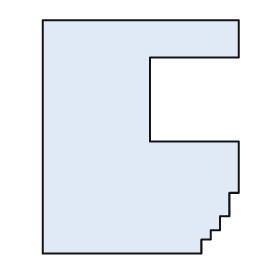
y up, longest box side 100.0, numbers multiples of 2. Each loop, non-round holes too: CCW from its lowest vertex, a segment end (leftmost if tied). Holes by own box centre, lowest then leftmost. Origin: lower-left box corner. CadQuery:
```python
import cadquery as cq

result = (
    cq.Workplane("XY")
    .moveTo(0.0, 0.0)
    .lineTo(68.0, 0.0)
    .lineTo(68.0, 6.0)
    .lineTo(72.0, 6.0)
    .lineTo(72.0, 10.0)
    .lineTo(76.0, 10.0)
    .lineTo(76.0, 16.0)
    .lineTo(80.0, 16.0)
    .lineTo(80.0, 26.0)
    .lineTo(84.0, 26.0)
    .lineTo(84.0, 48.0)
    .lineTo(46.0, 48.0)
    .lineTo(46.0, 84.0)
    .lineTo(84.0, 84.0)
    .lineTo(84.0, 100.0)
    .lineTo(0.0, 100.0)
    .close()
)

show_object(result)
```